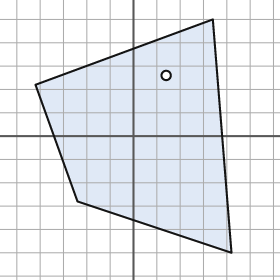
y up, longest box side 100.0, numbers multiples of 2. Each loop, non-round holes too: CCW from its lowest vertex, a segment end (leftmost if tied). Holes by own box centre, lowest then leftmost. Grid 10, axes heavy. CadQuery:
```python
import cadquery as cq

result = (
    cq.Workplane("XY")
    .moveTo(42.0, -50.0)
    .lineTo(34.0, 50.0)
    .lineTo(-42.0, 22.0)
    .lineTo(-24.0, -28.0)
    .close()
    .moveTo(14.0, 26.0)
    .circle(2.0)
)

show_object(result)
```